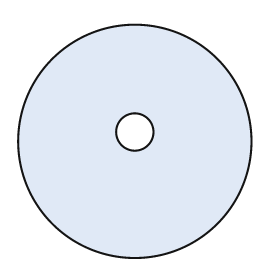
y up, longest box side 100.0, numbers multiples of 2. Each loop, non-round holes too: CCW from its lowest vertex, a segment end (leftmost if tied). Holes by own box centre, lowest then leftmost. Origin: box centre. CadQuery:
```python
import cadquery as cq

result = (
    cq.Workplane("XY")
    .moveTo(0.0, 0.0)
    .circle(50.0)
    .moveTo(0.0, 4.0)
    .circle(8.0)
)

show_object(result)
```